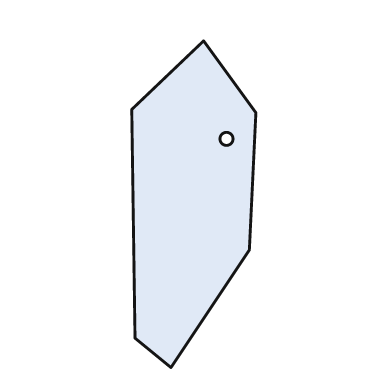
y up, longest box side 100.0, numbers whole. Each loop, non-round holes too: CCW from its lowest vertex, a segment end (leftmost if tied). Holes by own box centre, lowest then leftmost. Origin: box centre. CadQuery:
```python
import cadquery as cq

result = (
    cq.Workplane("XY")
    .moveTo(-7.0, -50.0)
    .lineTo(17.0, -14.0)
    .lineTo(19.0, 28.0)
    .lineTo(3.0, 50.0)
    .lineTo(-19.0, 29.0)
    .lineTo(-18.0, -41.0)
    .close()
    .moveTo(10.0, 20.0)
    .circle(2.0)
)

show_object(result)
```